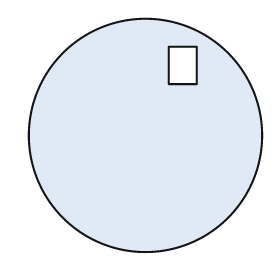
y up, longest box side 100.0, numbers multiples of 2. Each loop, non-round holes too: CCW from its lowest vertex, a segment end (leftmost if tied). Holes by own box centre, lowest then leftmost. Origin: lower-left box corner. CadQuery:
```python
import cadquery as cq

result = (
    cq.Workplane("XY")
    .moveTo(50.0, 50.0)
    .circle(50.0)
    .moveTo(60.0, 72.0)
    .lineTo(72.0, 72.0)
    .lineTo(72.0, 88.0)
    .lineTo(60.0, 88.0)
    .close()
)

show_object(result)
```